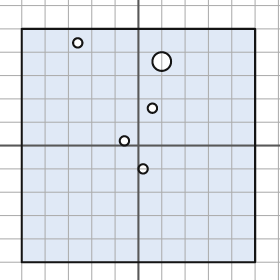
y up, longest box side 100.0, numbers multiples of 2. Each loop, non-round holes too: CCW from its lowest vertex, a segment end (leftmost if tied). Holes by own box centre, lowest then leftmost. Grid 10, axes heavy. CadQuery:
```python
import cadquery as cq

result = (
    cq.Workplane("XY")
    .moveTo(-50.0, -50.0)
    .lineTo(50.0, -50.0)
    .lineTo(50.0, 50.0)
    .lineTo(-50.0, 50.0)
    .close()
    .moveTo(2.0, -10.0)
    .circle(2.0)
    .moveTo(-6.0, 2.0)
    .circle(2.0)
    .moveTo(6.0, 16.0)
    .circle(2.0)
    .moveTo(10.0, 36.0)
    .circle(4.0)
    .moveTo(-26.0, 44.0)
    .circle(2.0)
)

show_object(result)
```